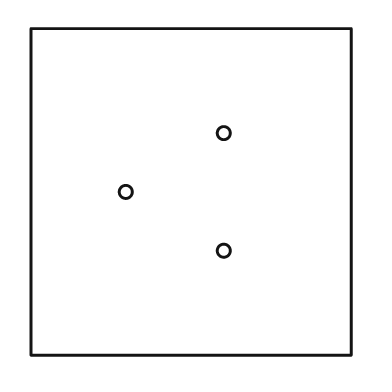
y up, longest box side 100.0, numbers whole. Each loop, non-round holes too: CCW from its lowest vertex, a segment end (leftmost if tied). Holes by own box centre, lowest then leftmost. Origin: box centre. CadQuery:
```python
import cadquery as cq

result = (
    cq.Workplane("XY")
    .moveTo(-49.0, -50.0)
    .lineTo(49.0, -50.0)
    .lineTo(49.0, 50.0)
    .lineTo(-49.0, 50.0)
    .close()
    .moveTo(10.0, -18.0)
    .circle(2.0)
    .moveTo(-20.0, 0.0)
    .circle(2.0)
    .moveTo(10.0, 18.0)
    .circle(2.0)
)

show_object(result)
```